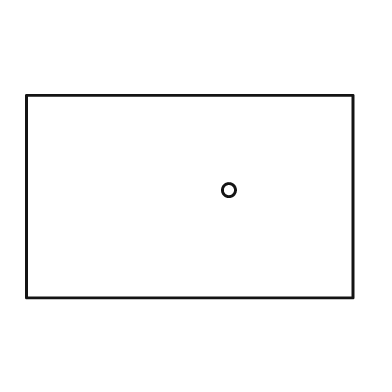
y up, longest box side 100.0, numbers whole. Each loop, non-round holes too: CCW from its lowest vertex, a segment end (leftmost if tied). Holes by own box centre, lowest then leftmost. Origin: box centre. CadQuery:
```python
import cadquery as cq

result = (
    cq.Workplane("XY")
    .moveTo(-50.0, -31.0)
    .lineTo(50.0, -31.0)
    .lineTo(50.0, 31.0)
    .lineTo(-50.0, 31.0)
    .close()
    .moveTo(12.0, 2.0)
    .circle(2.0)
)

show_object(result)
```